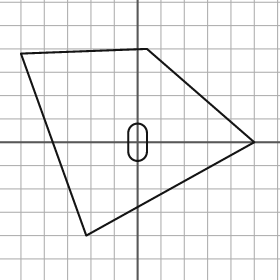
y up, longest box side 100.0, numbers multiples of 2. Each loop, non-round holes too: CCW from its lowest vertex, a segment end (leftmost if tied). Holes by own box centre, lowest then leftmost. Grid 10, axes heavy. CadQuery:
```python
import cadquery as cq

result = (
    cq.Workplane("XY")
    .moveTo(-22.0, -40.0)
    .lineTo(50.0, 0.0)
    .lineTo(4.0, 40.0)
    .lineTo(-50.0, 38.0)
    .close()
    .moveTo(-4.0, -4.0)
    .threePointArc((0.0, -8.0), (4.0, -4.0))
    .lineTo(4.0, 4.0)
    .threePointArc((0.0, 8.0), (-4.0, 4.0))
    .close()
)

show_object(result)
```